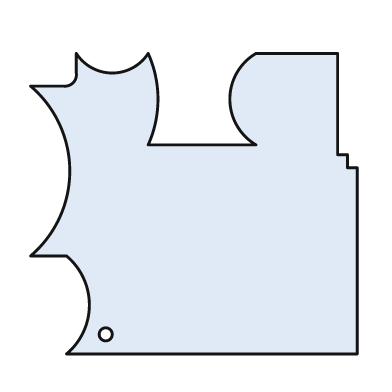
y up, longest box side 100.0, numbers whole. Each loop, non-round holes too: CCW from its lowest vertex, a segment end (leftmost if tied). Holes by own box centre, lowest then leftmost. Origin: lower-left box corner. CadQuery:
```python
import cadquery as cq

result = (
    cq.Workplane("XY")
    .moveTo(11.0, 0.0)
    .lineTo(100.0, 0.0)
    .lineTo(100.0, 57.0)
    .lineTo(97.0, 57.0)
    .lineTo(97.0, 61.0)
    .lineTo(94.0, 61.0)
    .lineTo(94.0, 92.0)
    .lineTo(69.0, 92.0)
    .threePointArc((61.0, 78.0), (69.0, 64.0))
    .lineTo(36.0, 64.0)
    .threePointArc((39.0, 78.0), (36.0, 92.0))
    .threePointArc((25.0, 86.0), (14.0, 92.0))
    .lineTo(14.0, 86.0)
    .threePointArc((13.0, 83.0), (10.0, 82.0))
    .lineTo(0.0, 82.0)
    .threePointArc((12.0, 56.0), (0.0, 30.0))
    .lineTo(11.0, 30.0)
    .threePointArc((18.0, 15.0), (11.0, 0.0))
    .close()
    .moveTo(23.0, 6.0)
    .circle(2.0)
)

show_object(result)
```